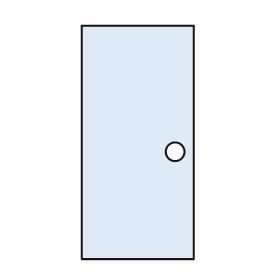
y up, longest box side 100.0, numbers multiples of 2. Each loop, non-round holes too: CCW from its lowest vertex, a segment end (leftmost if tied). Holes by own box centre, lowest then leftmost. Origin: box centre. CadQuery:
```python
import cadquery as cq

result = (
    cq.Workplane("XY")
    .moveTo(-24.0, -50.0)
    .lineTo(24.0, -50.0)
    .lineTo(24.0, 50.0)
    .lineTo(-24.0, 50.0)
    .close()
    .moveTo(16.0, -4.0)
    .circle(4.0)
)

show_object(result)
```